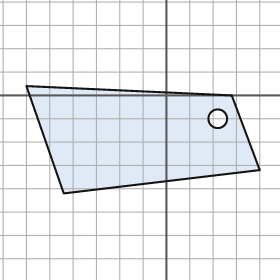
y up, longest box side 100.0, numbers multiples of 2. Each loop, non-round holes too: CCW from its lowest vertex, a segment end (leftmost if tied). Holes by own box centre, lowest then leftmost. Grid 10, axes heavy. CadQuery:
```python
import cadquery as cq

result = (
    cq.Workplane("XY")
    .moveTo(-44.0, -42.0)
    .lineTo(40.0, -32.0)
    .lineTo(28.0, 0.0)
    .lineTo(-60.0, 4.0)
    .close()
    .moveTo(22.0, -10.0)
    .circle(4.0)
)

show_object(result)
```